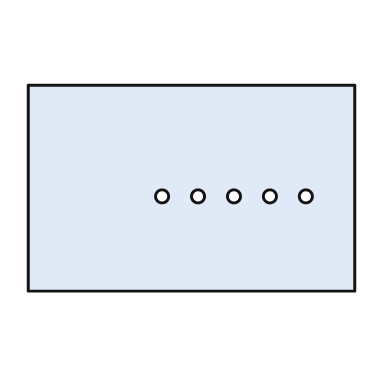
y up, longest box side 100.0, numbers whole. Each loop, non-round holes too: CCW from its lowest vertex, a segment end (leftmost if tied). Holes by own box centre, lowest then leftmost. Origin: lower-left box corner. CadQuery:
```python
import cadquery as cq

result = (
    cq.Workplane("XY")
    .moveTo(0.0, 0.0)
    .lineTo(100.0, 0.0)
    .lineTo(100.0, 63.0)
    .lineTo(0.0, 63.0)
    .close()
    .moveTo(41.0, 29.0)
    .circle(2.0)
    .moveTo(52.0, 29.0)
    .circle(2.0)
    .moveTo(63.0, 29.0)
    .circle(2.0)
    .moveTo(74.0, 29.0)
    .circle(2.0)
    .moveTo(85.0, 29.0)
    .circle(2.0)
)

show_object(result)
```